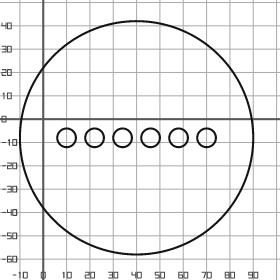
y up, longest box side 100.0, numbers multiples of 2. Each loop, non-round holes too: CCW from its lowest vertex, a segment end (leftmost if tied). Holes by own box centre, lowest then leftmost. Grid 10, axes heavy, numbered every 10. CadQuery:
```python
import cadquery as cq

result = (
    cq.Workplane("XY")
    .moveTo(40.0, -8.0)
    .circle(50.0)
    .moveTo(10.0, -8.0)
    .circle(4.0)
    .moveTo(22.0, -8.0)
    .circle(4.0)
    .moveTo(34.0, -8.0)
    .circle(4.0)
    .moveTo(46.0, -8.0)
    .circle(4.0)
    .moveTo(58.0, -8.0)
    .circle(4.0)
    .moveTo(70.0, -8.0)
    .circle(4.0)
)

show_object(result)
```